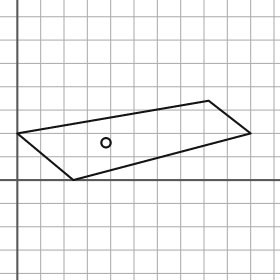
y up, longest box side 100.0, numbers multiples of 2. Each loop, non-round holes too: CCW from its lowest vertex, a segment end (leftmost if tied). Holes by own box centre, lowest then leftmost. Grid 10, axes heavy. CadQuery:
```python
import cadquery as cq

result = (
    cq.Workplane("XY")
    .moveTo(24.0, 0.0)
    .lineTo(100.0, 20.0)
    .lineTo(82.0, 34.0)
    .lineTo(0.0, 20.0)
    .close()
    .moveTo(38.0, 16.0)
    .circle(2.0)
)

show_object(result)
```